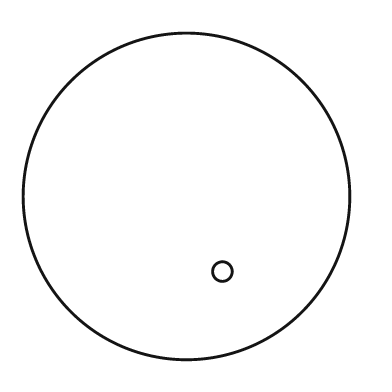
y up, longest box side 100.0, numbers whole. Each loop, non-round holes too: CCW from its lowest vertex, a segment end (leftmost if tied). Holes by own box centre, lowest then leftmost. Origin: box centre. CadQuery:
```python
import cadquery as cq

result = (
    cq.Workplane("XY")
    .moveTo(0.0, 0.0)
    .circle(50.0)
    .moveTo(11.0, -23.0)
    .circle(3.0)
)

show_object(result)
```